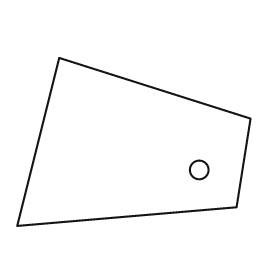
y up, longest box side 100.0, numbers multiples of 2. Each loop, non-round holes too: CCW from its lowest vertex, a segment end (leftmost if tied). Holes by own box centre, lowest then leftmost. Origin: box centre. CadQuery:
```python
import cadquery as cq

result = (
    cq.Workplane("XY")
    .moveTo(-50.0, -36.0)
    .lineTo(44.0, -28.0)
    .lineTo(50.0, 10.0)
    .lineTo(-32.0, 36.0)
    .close()
    .moveTo(28.0, -12.0)
    .circle(4.0)
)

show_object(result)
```